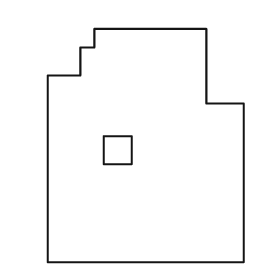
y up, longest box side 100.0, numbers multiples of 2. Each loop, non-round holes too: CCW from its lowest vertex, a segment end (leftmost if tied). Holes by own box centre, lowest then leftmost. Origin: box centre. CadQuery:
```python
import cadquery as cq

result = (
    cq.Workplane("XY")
    .moveTo(-42.0, -50.0)
    .lineTo(42.0, -50.0)
    .lineTo(42.0, 18.0)
    .lineTo(26.0, 18.0)
    .lineTo(26.0, 50.0)
    .lineTo(-22.0, 50.0)
    .lineTo(-22.0, 42.0)
    .lineTo(-28.0, 42.0)
    .lineTo(-28.0, 30.0)
    .lineTo(-42.0, 30.0)
    .close()
    .moveTo(-18.0, -8.0)
    .lineTo(-6.0, -8.0)
    .lineTo(-6.0, 4.0)
    .lineTo(-18.0, 4.0)
    .close()
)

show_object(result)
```